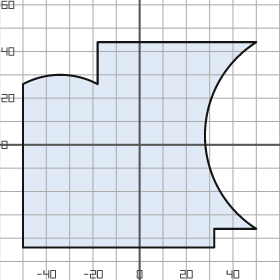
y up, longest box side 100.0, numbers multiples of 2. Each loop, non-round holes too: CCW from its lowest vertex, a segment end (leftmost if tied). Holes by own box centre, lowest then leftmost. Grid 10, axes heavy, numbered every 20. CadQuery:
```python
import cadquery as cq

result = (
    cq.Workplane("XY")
    .moveTo(-50.0, -44.0)
    .lineTo(32.0, -44.0)
    .lineTo(32.0, -36.0)
    .lineTo(50.0, -36.0)
    .threePointArc((28.0, 4.0), (50.0, 44.0))
    .lineTo(-18.0, 44.0)
    .lineTo(-18.0, 26.0)
    .threePointArc((-34.0, 30.0), (-50.0, 26.0))
    .close()
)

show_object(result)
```